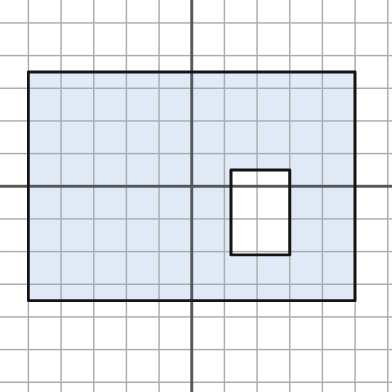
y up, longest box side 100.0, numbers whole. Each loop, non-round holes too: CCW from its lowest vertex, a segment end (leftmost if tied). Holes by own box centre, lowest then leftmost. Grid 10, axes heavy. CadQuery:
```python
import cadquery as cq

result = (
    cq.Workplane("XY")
    .moveTo(-50.0, -35.0)
    .lineTo(50.0, -35.0)
    .lineTo(50.0, 35.0)
    .lineTo(-50.0, 35.0)
    .close()
    .moveTo(12.0, -21.0)
    .lineTo(30.0, -21.0)
    .lineTo(30.0, 5.0)
    .lineTo(12.0, 5.0)
    .close()
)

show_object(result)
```